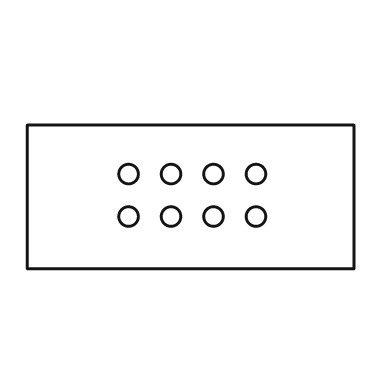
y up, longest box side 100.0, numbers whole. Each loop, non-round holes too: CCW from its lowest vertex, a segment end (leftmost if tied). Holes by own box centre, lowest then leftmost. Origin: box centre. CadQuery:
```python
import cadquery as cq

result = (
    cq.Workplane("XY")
    .moveTo(-50.0, -22.0)
    .lineTo(50.0, -22.0)
    .lineTo(50.0, 22.0)
    .lineTo(-50.0, 22.0)
    .close()
    .moveTo(-19.0, -6.0)
    .circle(3.0)
    .moveTo(-6.0, -6.0)
    .circle(3.0)
    .moveTo(7.0, -6.0)
    .circle(3.0)
    .moveTo(20.0, -6.0)
    .circle(3.0)
    .moveTo(-19.0, 7.0)
    .circle(3.0)
    .moveTo(-6.0, 7.0)
    .circle(3.0)
    .moveTo(7.0, 7.0)
    .circle(3.0)
    .moveTo(20.0, 7.0)
    .circle(3.0)
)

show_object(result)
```